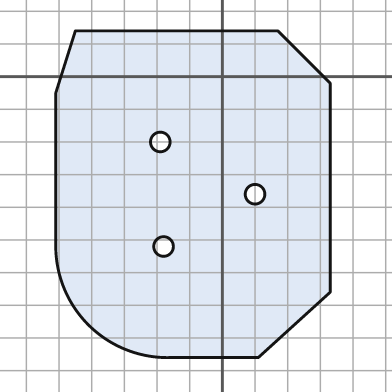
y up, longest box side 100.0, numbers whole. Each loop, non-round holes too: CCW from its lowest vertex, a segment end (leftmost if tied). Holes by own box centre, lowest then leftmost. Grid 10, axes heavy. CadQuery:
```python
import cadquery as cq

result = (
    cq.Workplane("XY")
    .moveTo(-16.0, -86.0)
    .lineTo(11.0, -86.0)
    .lineTo(33.0, -66.0)
    .lineTo(33.0, -2.0)
    .lineTo(17.0, 14.0)
    .lineTo(-45.0, 14.0)
    .lineTo(-51.0, -5.0)
    .lineTo(-51.0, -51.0)
    .threePointArc((-41.0, -76.0), (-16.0, -86.0))
    .close()
    .moveTo(-18.0, -52.0)
    .circle(3.0)
    .moveTo(10.0, -36.0)
    .circle(3.0)
    .moveTo(-19.0, -20.0)
    .circle(3.0)
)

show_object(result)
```